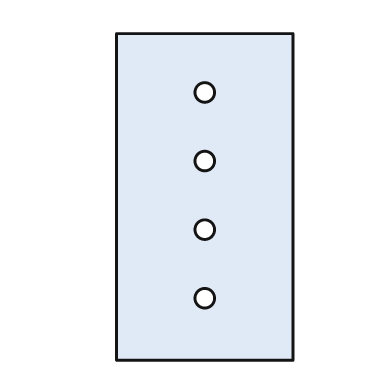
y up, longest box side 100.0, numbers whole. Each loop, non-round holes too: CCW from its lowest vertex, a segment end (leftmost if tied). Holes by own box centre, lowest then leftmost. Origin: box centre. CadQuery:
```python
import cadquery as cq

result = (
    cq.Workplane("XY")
    .moveTo(-27.0, -50.0)
    .lineTo(27.0, -50.0)
    .lineTo(27.0, 50.0)
    .lineTo(-27.0, 50.0)
    .close()
    .moveTo(0.0, -31.0)
    .circle(3.0)
    .moveTo(0.0, -10.0)
    .circle(3.0)
    .moveTo(0.0, 11.0)
    .circle(3.0)
    .moveTo(0.0, 32.0)
    .circle(3.0)
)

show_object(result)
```